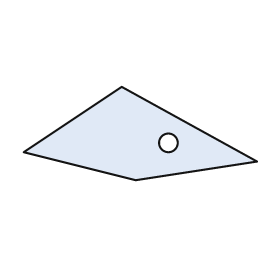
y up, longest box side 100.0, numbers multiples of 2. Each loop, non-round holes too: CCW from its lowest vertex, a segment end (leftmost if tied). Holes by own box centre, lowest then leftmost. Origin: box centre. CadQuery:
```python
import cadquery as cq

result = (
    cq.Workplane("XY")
    .moveTo(-2.0, -20.0)
    .lineTo(50.0, -12.0)
    .lineTo(-8.0, 20.0)
    .lineTo(-50.0, -8.0)
    .close()
    .moveTo(12.0, -4.0)
    .circle(4.0)
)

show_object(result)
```